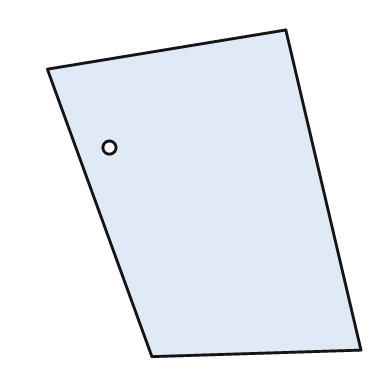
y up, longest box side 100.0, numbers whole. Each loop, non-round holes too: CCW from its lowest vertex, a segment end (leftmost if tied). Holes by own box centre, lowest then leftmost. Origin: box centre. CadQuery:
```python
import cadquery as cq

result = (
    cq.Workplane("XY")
    .moveTo(-16.0, -50.0)
    .lineTo(48.0, -48.0)
    .lineTo(25.0, 50.0)
    .lineTo(-48.0, 38.0)
    .close()
    .moveTo(-29.0, 14.0)
    .circle(2.0)
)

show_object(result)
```